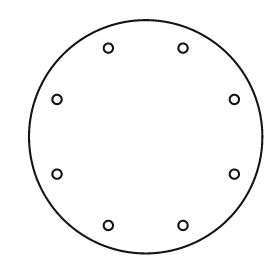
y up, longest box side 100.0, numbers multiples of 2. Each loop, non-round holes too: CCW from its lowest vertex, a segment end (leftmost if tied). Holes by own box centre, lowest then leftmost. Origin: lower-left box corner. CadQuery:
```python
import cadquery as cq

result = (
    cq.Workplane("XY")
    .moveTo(50.0, 50.0)
    .circle(50.0)
    .moveTo(34.0, 12.0)
    .circle(2.0)
    .moveTo(66.0, 12.0)
    .circle(2.0)
    .moveTo(12.0, 34.0)
    .circle(2.0)
    .moveTo(88.0, 34.0)
    .circle(2.0)
    .moveTo(12.0, 66.0)
    .circle(2.0)
    .moveTo(88.0, 66.0)
    .circle(2.0)
    .moveTo(34.0, 88.0)
    .circle(2.0)
    .moveTo(66.0, 88.0)
    .circle(2.0)
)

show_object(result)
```